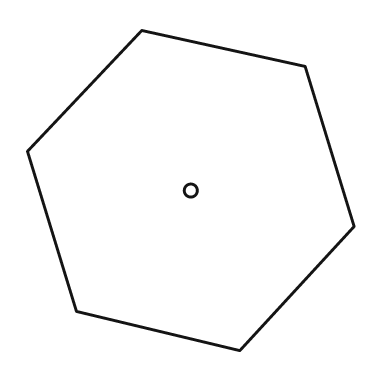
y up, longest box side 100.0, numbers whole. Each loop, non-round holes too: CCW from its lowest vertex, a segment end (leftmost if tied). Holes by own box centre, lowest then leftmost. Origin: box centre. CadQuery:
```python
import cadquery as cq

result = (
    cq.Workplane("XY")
    .moveTo(15.0, -49.0)
    .lineTo(50.0, -11.0)
    .lineTo(35.0, 38.0)
    .lineTo(-15.0, 49.0)
    .lineTo(-50.0, 12.0)
    .lineTo(-35.0, -37.0)
    .close()
    .moveTo(0.0, 0.0)
    .circle(2.0)
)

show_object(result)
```